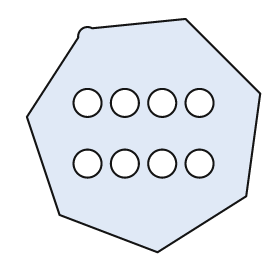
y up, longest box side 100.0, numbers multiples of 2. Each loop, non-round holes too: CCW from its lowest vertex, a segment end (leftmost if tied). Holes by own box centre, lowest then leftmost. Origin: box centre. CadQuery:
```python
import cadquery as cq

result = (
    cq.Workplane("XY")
    .moveTo(6.0, -50.0)
    .lineTo(44.0, -26.0)
    .lineTo(50.0, 18.0)
    .lineTo(18.0, 50.0)
    .lineTo(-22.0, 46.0)
    .threePointArc((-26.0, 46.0), (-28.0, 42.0))
    .lineTo(-50.0, 8.0)
    .lineTo(-36.0, -34.0)
    .close()
    .moveTo(-24.0, -12.0)
    .circle(6.0)
    .moveTo(-8.0, -12.0)
    .circle(6.0)
    .moveTo(8.0, -12.0)
    .circle(6.0)
    .moveTo(24.0, -12.0)
    .circle(6.0)
    .moveTo(-24.0, 14.0)
    .circle(6.0)
    .moveTo(-8.0, 14.0)
    .circle(6.0)
    .moveTo(8.0, 14.0)
    .circle(6.0)
    .moveTo(24.0, 14.0)
    .circle(6.0)
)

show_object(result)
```